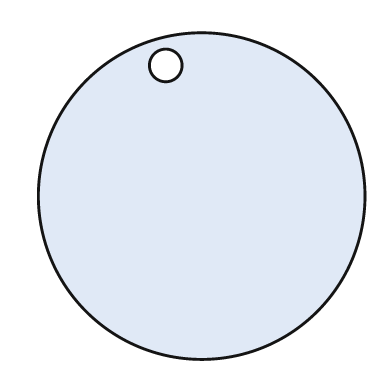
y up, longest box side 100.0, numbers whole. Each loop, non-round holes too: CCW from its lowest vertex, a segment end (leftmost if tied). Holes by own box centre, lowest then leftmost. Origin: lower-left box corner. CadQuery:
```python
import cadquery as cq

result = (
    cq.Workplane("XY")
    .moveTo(50.0, 50.0)
    .circle(50.0)
    .moveTo(39.0, 90.0)
    .circle(5.0)
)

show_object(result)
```